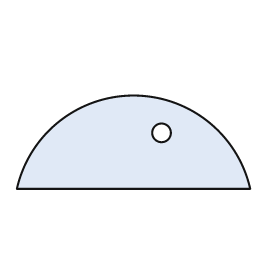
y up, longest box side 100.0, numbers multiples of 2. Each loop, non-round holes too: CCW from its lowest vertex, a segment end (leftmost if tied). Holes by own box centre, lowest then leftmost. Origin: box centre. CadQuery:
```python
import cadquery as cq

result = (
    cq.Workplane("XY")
    .moveTo(-50.0, -20.0)
    .lineTo(50.0, -20.0)
    .threePointArc((0.0, 20.0), (-50.0, -20.0))
    .close()
    .moveTo(12.0, 4.0)
    .circle(4.0)
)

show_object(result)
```